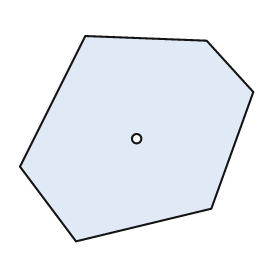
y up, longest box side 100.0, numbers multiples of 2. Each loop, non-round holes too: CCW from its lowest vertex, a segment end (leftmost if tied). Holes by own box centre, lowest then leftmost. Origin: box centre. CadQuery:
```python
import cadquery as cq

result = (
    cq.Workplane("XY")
    .moveTo(-26.0, -44.0)
    .lineTo(32.0, -30.0)
    .lineTo(50.0, 20.0)
    .lineTo(30.0, 42.0)
    .lineTo(-22.0, 44.0)
    .lineTo(-50.0, -12.0)
    .close()
    .moveTo(0.0, 0.0)
    .circle(2.0)
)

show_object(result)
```